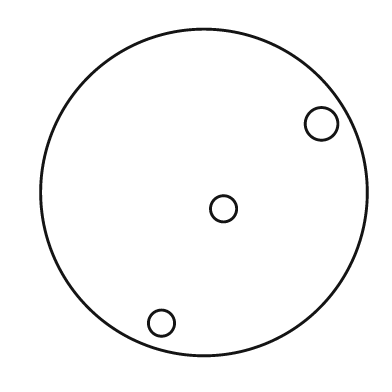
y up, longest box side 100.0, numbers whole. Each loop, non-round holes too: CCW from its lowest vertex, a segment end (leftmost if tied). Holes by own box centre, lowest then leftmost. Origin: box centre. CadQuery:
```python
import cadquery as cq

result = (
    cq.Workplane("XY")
    .moveTo(0.0, 0.0)
    .circle(50.0)
    .moveTo(-13.0, -40.0)
    .circle(4.0)
    .moveTo(6.0, -5.0)
    .circle(4.0)
    .moveTo(36.0, 21.0)
    .circle(5.0)
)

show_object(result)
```